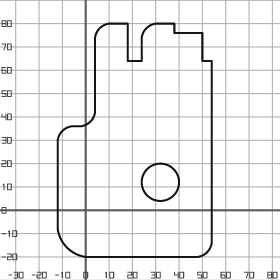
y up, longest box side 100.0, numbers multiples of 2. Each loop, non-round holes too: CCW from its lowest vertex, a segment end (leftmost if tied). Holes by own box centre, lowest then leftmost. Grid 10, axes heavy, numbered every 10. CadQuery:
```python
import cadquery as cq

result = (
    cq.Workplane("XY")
    .moveTo(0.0, -20.0)
    .lineTo(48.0, -20.0)
    .threePointArc((52.0, -18.0), (54.0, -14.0))
    .lineTo(54.0, 64.0)
    .lineTo(50.0, 64.0)
    .lineTo(50.0, 76.0)
    .lineTo(38.0, 76.0)
    .lineTo(38.0, 80.0)
    .lineTo(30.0, 80.0)
    .threePointArc((26.0, 78.0), (24.0, 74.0))
    .lineTo(24.0, 64.0)
    .lineTo(18.0, 64.0)
    .lineTo(18.0, 80.0)
    .lineTo(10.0, 80.0)
    .threePointArc((6.0, 78.0), (4.0, 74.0))
    .lineTo(4.0, 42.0)
    .threePointArc((2.0, 38.0), (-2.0, 36.0))
    .lineTo(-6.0, 36.0)
    .threePointArc((-10.0, 34.0), (-12.0, 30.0))
    .lineTo(-12.0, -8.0)
    .threePointArc((-8.0, -16.0), (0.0, -20.0))
    .close()
    .moveTo(32.0, 12.0)
    .circle(8.0)
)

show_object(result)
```